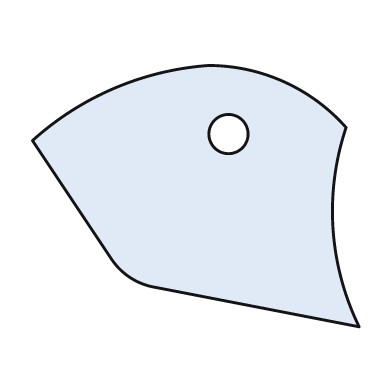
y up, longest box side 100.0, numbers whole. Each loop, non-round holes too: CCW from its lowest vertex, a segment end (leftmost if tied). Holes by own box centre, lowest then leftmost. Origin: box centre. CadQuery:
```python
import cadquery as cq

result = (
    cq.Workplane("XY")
    .moveTo(50.0, -40.0)
    .threePointArc((42.0, -10.0), (46.0, 21.0))
    .threePointArc((27.0, 35.0), (4.0, 40.0))
    .threePointArc((-25.0, 33.0), (-50.0, 17.0))
    .lineTo(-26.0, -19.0)
    .threePointArc((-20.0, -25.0), (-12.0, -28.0))
    .close()
    .moveTo(10.0, 19.0)
    .circle(6.0)
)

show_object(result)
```